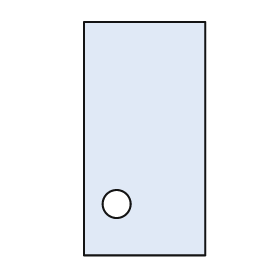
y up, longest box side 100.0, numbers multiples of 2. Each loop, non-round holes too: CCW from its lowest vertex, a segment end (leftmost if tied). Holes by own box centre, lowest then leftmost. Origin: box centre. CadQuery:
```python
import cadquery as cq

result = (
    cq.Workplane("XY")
    .moveTo(-26.0, -50.0)
    .lineTo(26.0, -50.0)
    .lineTo(26.0, 50.0)
    .lineTo(-26.0, 50.0)
    .close()
    .moveTo(-12.0, -28.0)
    .circle(6.0)
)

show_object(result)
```